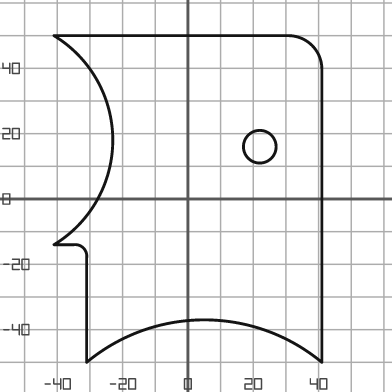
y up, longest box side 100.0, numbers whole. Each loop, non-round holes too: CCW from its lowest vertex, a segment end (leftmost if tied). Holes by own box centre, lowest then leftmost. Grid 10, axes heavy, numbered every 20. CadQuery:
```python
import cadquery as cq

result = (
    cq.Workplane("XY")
    .moveTo(-31.0, -50.0)
    .threePointArc((5.0, -37.0), (41.0, -50.0))
    .lineTo(41.0, 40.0)
    .threePointArc((38.0, 47.0), (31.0, 50.0))
    .lineTo(-41.0, 50.0)
    .threePointArc((-23.0, 18.0), (-41.0, -14.0))
    .lineTo(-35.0, -14.0)
    .threePointArc((-32.0, -15.0), (-31.0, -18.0))
    .close()
    .moveTo(22.0, 16.0)
    .circle(5.0)
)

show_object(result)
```